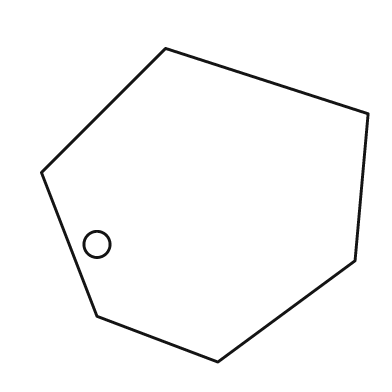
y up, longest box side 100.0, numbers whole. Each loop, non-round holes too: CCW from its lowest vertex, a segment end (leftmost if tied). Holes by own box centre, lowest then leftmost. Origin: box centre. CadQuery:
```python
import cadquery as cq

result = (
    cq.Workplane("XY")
    .moveTo(4.0, -48.0)
    .lineTo(46.0, -17.0)
    .lineTo(50.0, 28.0)
    .lineTo(-12.0, 48.0)
    .lineTo(-50.0, 10.0)
    .lineTo(-33.0, -34.0)
    .close()
    .moveTo(-33.0, -12.0)
    .circle(4.0)
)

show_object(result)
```